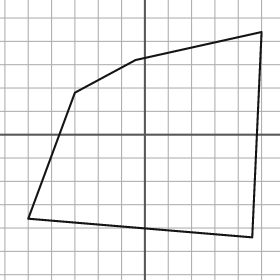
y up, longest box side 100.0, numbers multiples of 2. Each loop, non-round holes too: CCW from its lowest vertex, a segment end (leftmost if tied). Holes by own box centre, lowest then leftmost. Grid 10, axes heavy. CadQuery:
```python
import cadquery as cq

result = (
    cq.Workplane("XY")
    .moveTo(46.0, -44.0)
    .lineTo(50.0, 44.0)
    .lineTo(-4.0, 32.0)
    .lineTo(-30.0, 18.0)
    .lineTo(-50.0, -36.0)
    .close()
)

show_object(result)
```